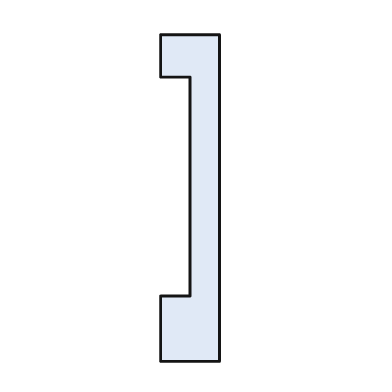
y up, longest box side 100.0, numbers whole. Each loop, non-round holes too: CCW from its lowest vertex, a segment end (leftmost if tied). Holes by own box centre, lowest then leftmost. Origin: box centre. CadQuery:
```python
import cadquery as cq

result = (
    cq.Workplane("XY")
    .moveTo(-9.0, -50.0)
    .lineTo(9.0, -50.0)
    .lineTo(9.0, 50.0)
    .lineTo(-9.0, 50.0)
    .lineTo(-9.0, 37.0)
    .lineTo(0.0, 37.0)
    .lineTo(0.0, -30.0)
    .lineTo(-9.0, -30.0)
    .close()
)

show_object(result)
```